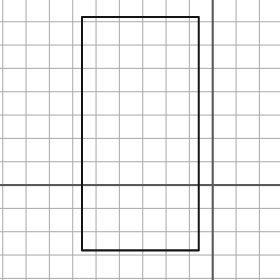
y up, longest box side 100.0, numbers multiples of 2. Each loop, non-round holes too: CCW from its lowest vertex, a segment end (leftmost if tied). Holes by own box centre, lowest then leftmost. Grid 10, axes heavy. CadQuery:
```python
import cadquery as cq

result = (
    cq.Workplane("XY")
    .moveTo(-56.0, -28.0)
    .lineTo(-6.0, -28.0)
    .lineTo(-6.0, 72.0)
    .lineTo(-56.0, 72.0)
    .close()
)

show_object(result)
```